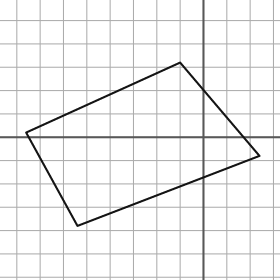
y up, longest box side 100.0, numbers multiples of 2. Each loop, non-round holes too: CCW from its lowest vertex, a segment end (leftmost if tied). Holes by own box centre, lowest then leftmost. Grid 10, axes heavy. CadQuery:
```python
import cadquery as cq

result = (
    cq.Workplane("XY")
    .moveTo(-54.0, -38.0)
    .lineTo(24.0, -8.0)
    .lineTo(-10.0, 32.0)
    .lineTo(-76.0, 2.0)
    .close()
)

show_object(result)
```